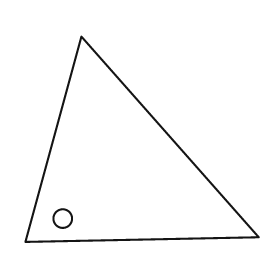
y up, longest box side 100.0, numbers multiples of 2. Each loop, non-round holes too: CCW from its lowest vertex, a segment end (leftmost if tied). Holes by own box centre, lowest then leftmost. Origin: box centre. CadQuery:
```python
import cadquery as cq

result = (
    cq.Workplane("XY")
    .moveTo(-50.0, -44.0)
    .lineTo(50.0, -42.0)
    .lineTo(-26.0, 44.0)
    .close()
    .moveTo(-34.0, -34.0)
    .circle(4.0)
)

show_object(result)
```